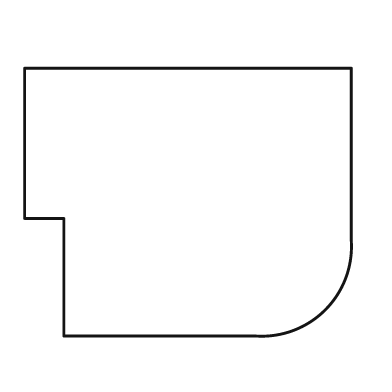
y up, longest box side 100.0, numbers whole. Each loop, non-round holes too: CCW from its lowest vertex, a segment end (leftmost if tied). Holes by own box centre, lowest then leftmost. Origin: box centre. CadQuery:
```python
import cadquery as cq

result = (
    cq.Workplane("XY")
    .moveTo(-38.0, -41.0)
    .lineTo(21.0, -41.0)
    .threePointArc((42.0, -33.0), (50.0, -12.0))
    .lineTo(50.0, 41.0)
    .lineTo(-50.0, 41.0)
    .lineTo(-50.0, -5.0)
    .lineTo(-38.0, -5.0)
    .close()
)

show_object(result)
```